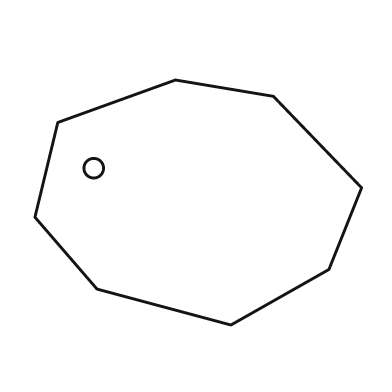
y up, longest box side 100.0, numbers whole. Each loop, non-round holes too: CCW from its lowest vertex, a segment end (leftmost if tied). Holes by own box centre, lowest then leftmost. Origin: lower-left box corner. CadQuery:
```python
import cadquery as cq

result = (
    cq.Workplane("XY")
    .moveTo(60.0, 0.0)
    .lineTo(90.0, 17.0)
    .lineTo(100.0, 42.0)
    .lineTo(73.0, 70.0)
    .lineTo(43.0, 75.0)
    .lineTo(7.0, 62.0)
    .lineTo(0.0, 33.0)
    .lineTo(19.0, 11.0)
    .close()
    .moveTo(18.0, 48.0)
    .circle(3.0)
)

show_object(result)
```